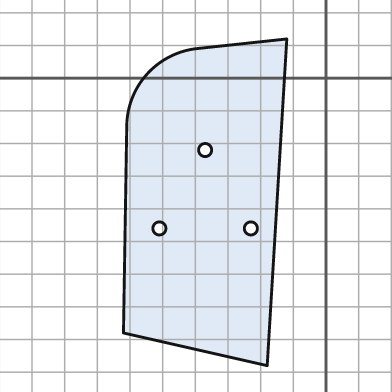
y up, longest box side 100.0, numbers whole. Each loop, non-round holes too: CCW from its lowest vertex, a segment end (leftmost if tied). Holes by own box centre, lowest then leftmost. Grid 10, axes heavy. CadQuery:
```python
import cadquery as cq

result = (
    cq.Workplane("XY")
    .moveTo(-18.0, -88.0)
    .lineTo(-12.0, 12.0)
    .lineTo(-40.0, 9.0)
    .threePointArc((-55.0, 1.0), (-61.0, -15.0))
    .lineTo(-62.0, -78.0)
    .close()
    .moveTo(-51.0, -46.0)
    .circle(2.0)
    .moveTo(-23.0, -46.0)
    .circle(2.0)
    .moveTo(-37.0, -22.0)
    .circle(2.0)
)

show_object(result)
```